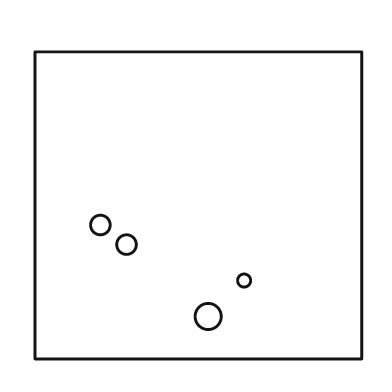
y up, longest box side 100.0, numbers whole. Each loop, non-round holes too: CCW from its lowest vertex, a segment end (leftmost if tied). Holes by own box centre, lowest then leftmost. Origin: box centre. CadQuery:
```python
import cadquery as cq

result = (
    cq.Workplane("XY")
    .moveTo(-50.0, -47.0)
    .lineTo(50.0, -47.0)
    .lineTo(50.0, 47.0)
    .lineTo(-50.0, 47.0)
    .close()
    .moveTo(3.0, -34.0)
    .circle(4.0)
    .moveTo(14.0, -23.0)
    .circle(2.0)
    .moveTo(-22.0, -12.0)
    .circle(3.0)
    .moveTo(-30.0, -6.0)
    .circle(3.0)
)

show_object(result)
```